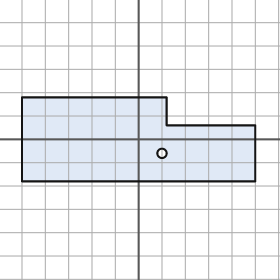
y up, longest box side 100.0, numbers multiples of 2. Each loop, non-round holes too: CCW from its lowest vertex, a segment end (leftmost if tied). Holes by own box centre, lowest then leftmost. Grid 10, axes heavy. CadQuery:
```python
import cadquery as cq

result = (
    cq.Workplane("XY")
    .moveTo(-50.0, -18.0)
    .lineTo(50.0, -18.0)
    .lineTo(50.0, 6.0)
    .lineTo(12.0, 6.0)
    .lineTo(12.0, 18.0)
    .lineTo(-50.0, 18.0)
    .close()
    .moveTo(10.0, -6.0)
    .circle(2.0)
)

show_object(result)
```